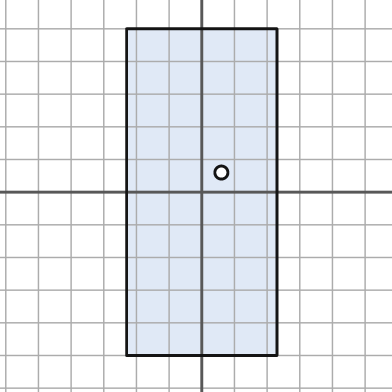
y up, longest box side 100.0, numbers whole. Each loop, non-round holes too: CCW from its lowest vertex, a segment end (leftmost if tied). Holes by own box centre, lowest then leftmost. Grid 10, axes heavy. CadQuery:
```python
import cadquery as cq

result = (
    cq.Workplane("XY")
    .moveTo(-23.0, -50.0)
    .lineTo(23.0, -50.0)
    .lineTo(23.0, 50.0)
    .lineTo(-23.0, 50.0)
    .close()
    .moveTo(6.0, 6.0)
    .circle(2.0)
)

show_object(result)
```